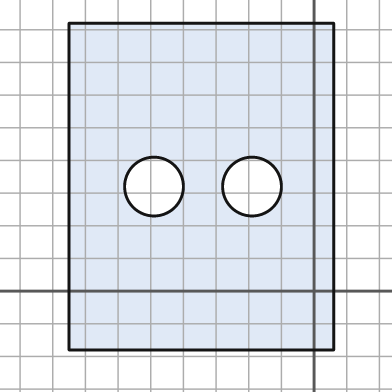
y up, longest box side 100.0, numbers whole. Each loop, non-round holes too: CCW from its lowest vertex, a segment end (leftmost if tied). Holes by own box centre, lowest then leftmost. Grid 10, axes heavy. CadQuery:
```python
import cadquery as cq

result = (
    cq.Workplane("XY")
    .moveTo(-75.0, -18.0)
    .lineTo(6.0, -18.0)
    .lineTo(6.0, 82.0)
    .lineTo(-75.0, 82.0)
    .close()
    .moveTo(-49.0, 32.0)
    .circle(9.0)
    .moveTo(-19.0, 32.0)
    .circle(9.0)
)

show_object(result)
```